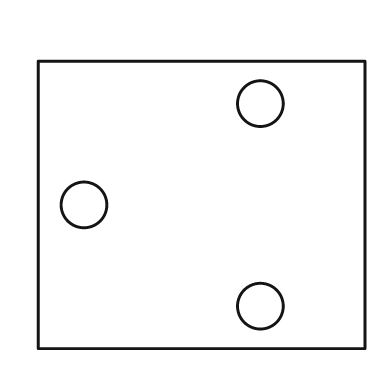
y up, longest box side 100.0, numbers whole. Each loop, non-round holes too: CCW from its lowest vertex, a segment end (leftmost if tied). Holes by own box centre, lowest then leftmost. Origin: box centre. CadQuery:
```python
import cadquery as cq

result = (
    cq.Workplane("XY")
    .moveTo(-50.0, -44.0)
    .lineTo(50.0, -44.0)
    .lineTo(50.0, 44.0)
    .lineTo(-50.0, 44.0)
    .close()
    .moveTo(18.0, -31.0)
    .circle(7.0)
    .moveTo(-36.0, 0.0)
    .circle(7.0)
    .moveTo(18.0, 31.0)
    .circle(7.0)
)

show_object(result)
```